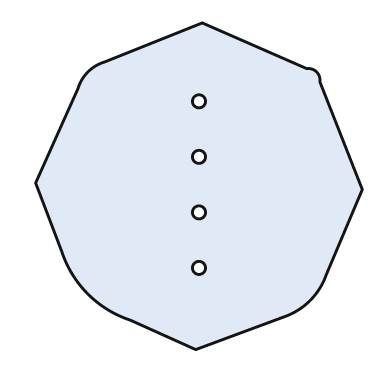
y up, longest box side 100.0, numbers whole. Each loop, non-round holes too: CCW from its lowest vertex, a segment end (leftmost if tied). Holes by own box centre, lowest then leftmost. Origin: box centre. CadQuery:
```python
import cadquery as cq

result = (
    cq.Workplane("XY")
    .moveTo(-1.0, -50.0)
    .lineTo(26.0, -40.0)
    .threePointArc((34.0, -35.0), (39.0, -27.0))
    .lineTo(50.0, -1.0)
    .lineTo(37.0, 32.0)
    .threePointArc((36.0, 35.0), (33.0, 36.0))
    .lineTo(1.0, 50.0)
    .lineTo(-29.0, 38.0)
    .threePointArc((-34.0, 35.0), (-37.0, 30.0))
    .lineTo(-50.0, 1.0)
    .lineTo(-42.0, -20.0)
    .threePointArc((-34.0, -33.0), (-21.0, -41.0))
    .close()
    .moveTo(0.0, -25.0)
    .circle(2.0)
    .moveTo(0.0, -8.0)
    .circle(2.0)
    .moveTo(0.0, 9.0)
    .circle(2.0)
    .moveTo(0.0, 26.0)
    .circle(2.0)
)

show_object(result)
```